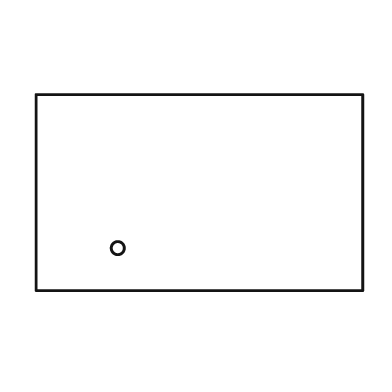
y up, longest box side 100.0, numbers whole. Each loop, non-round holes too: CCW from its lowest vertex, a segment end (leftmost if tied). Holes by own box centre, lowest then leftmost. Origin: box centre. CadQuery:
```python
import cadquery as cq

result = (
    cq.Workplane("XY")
    .moveTo(-50.0, -30.0)
    .lineTo(50.0, -30.0)
    .lineTo(50.0, 30.0)
    .lineTo(-50.0, 30.0)
    .close()
    .moveTo(-25.0, -17.0)
    .circle(2.0)
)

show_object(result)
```